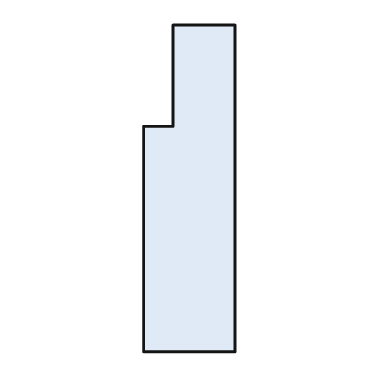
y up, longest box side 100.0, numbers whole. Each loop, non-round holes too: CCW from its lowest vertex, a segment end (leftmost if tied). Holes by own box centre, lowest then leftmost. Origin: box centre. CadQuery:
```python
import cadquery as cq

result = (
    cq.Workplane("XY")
    .moveTo(-14.0, -50.0)
    .lineTo(14.0, -50.0)
    .lineTo(14.0, 50.0)
    .lineTo(-5.0, 50.0)
    .lineTo(-5.0, 19.0)
    .lineTo(-14.0, 19.0)
    .close()
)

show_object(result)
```